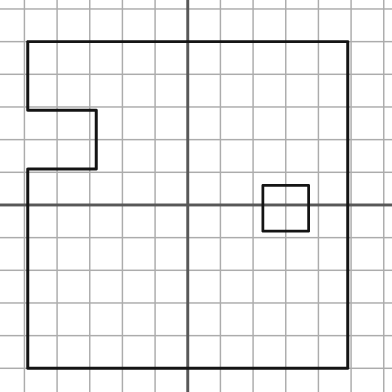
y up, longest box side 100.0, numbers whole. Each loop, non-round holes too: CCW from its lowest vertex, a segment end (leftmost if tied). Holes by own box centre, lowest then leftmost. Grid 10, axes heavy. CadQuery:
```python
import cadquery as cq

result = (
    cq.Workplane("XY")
    .moveTo(-49.0, -50.0)
    .lineTo(49.0, -50.0)
    .lineTo(49.0, 50.0)
    .lineTo(-49.0, 50.0)
    .lineTo(-49.0, 29.0)
    .lineTo(-28.0, 29.0)
    .lineTo(-28.0, 11.0)
    .lineTo(-49.0, 11.0)
    .close()
    .moveTo(23.0, -8.0)
    .lineTo(37.0, -8.0)
    .lineTo(37.0, 6.0)
    .lineTo(23.0, 6.0)
    .close()
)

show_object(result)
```